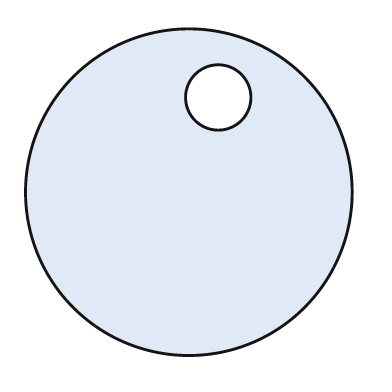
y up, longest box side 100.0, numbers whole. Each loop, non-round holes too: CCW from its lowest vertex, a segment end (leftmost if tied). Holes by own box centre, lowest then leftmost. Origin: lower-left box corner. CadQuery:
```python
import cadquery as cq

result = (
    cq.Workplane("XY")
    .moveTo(50.0, 50.0)
    .circle(50.0)
    .moveTo(59.0, 79.0)
    .circle(10.0)
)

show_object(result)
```